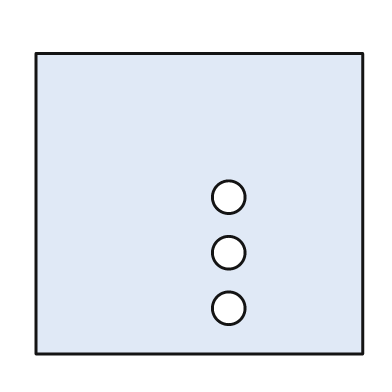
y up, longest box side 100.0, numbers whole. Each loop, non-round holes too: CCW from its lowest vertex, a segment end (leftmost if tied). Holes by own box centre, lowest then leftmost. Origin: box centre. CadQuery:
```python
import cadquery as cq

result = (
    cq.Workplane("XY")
    .moveTo(-50.0, -46.0)
    .lineTo(50.0, -46.0)
    .lineTo(50.0, 46.0)
    .lineTo(-50.0, 46.0)
    .close()
    .moveTo(9.0, -32.0)
    .circle(5.0)
    .moveTo(9.0, -15.0)
    .circle(5.0)
    .moveTo(9.0, 2.0)
    .circle(5.0)
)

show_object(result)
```